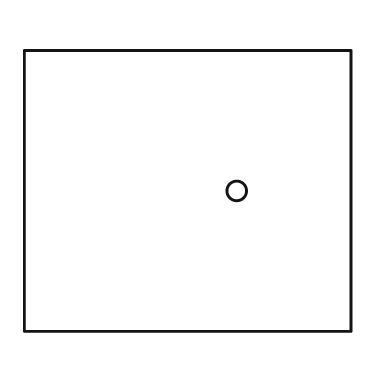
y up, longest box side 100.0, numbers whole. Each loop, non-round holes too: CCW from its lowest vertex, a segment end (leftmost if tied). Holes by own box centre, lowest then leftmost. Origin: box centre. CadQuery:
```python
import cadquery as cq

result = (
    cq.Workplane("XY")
    .moveTo(-50.0, -43.0)
    .lineTo(50.0, -43.0)
    .lineTo(50.0, 43.0)
    .lineTo(-50.0, 43.0)
    .close()
    .moveTo(15.0, 0.0)
    .circle(3.0)
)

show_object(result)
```